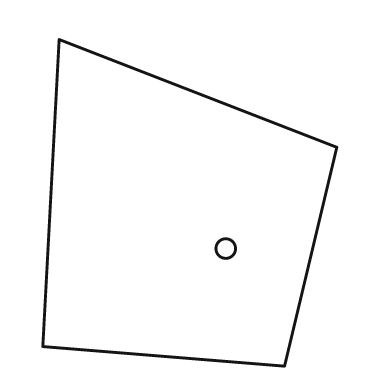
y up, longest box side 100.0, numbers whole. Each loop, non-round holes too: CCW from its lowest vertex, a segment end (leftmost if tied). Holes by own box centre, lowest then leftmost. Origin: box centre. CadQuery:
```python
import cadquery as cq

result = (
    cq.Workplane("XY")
    .moveTo(29.0, -50.0)
    .lineTo(45.0, 17.0)
    .lineTo(-40.0, 50.0)
    .lineTo(-45.0, -44.0)
    .close()
    .moveTo(11.0, -14.0)
    .circle(3.0)
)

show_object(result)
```